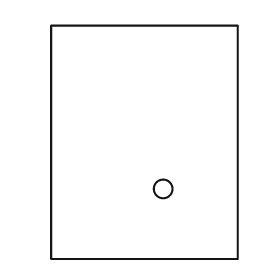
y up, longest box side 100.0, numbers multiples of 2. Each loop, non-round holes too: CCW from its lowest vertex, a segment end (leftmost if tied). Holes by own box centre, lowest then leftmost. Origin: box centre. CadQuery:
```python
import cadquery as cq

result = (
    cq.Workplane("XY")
    .moveTo(-40.0, -50.0)
    .lineTo(40.0, -50.0)
    .lineTo(40.0, 50.0)
    .lineTo(-40.0, 50.0)
    .close()
    .moveTo(8.0, -20.0)
    .circle(4.0)
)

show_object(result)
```